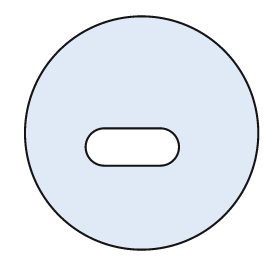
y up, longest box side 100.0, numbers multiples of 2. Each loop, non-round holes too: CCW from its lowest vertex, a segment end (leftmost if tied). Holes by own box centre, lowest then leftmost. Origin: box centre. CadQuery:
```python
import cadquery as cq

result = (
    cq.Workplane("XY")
    .moveTo(0.0, 0.0)
    .circle(50.0)
    .moveTo(-16.0, -14.0)
    .lineTo(8.0, -14.0)
    .threePointArc((16.0, -6.0), (8.0, 2.0))
    .lineTo(-16.0, 2.0)
    .threePointArc((-24.0, -6.0), (-16.0, -14.0))
    .close()
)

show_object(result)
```